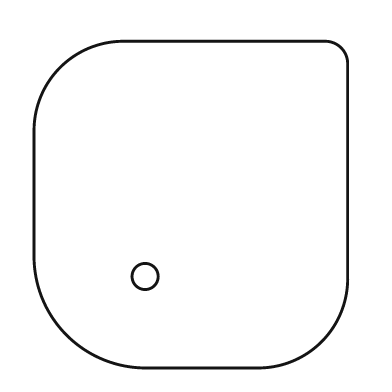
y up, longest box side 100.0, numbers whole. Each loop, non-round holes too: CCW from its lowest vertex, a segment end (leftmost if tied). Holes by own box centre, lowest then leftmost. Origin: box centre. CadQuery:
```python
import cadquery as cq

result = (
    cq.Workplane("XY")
    .moveTo(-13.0, -50.0)
    .lineTo(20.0, -50.0)
    .threePointArc((40.0, -42.0), (48.0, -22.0))
    .lineTo(48.0, 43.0)
    .threePointArc((46.0, 48.0), (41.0, 50.0))
    .lineTo(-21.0, 50.0)
    .threePointArc((-40.0, 42.0), (-48.0, 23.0))
    .lineTo(-48.0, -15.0)
    .threePointArc((-38.0, -40.0), (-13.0, -50.0))
    .close()
    .moveTo(-14.0, -22.0)
    .circle(4.0)
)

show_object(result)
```